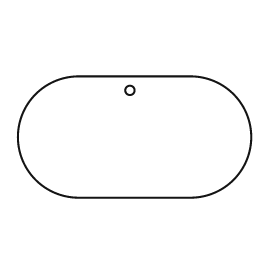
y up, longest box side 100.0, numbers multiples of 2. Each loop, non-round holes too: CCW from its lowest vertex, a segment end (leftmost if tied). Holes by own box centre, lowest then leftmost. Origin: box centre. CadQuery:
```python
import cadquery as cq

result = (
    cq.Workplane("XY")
    .moveTo(-24.0, -26.0)
    .lineTo(24.0, -26.0)
    .threePointArc((50.0, 0.0), (24.0, 26.0))
    .lineTo(-24.0, 26.0)
    .threePointArc((-50.0, 0.0), (-24.0, -26.0))
    .close()
    .moveTo(-2.0, 20.0)
    .circle(2.0)
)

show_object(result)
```